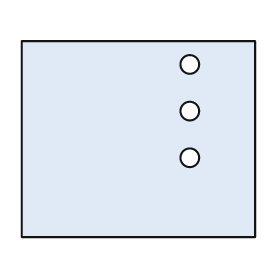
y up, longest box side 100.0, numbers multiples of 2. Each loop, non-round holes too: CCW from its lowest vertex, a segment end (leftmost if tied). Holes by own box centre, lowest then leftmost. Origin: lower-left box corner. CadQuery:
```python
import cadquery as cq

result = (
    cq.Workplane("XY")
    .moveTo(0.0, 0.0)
    .lineTo(100.0, 0.0)
    .lineTo(100.0, 84.0)
    .lineTo(0.0, 84.0)
    .close()
    .moveTo(72.0, 34.0)
    .circle(4.0)
    .moveTo(72.0, 54.0)
    .circle(4.0)
    .moveTo(72.0, 74.0)
    .circle(4.0)
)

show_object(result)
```